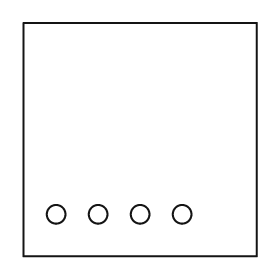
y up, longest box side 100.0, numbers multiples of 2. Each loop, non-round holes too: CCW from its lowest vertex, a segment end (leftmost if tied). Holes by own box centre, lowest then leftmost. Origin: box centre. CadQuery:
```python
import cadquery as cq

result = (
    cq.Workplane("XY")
    .moveTo(-50.0, -50.0)
    .lineTo(50.0, -50.0)
    .lineTo(50.0, 50.0)
    .lineTo(-50.0, 50.0)
    .close()
    .moveTo(-36.0, -32.0)
    .circle(4.0)
    .moveTo(-18.0, -32.0)
    .circle(4.0)
    .moveTo(0.0, -32.0)
    .circle(4.0)
    .moveTo(18.0, -32.0)
    .circle(4.0)
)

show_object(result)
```